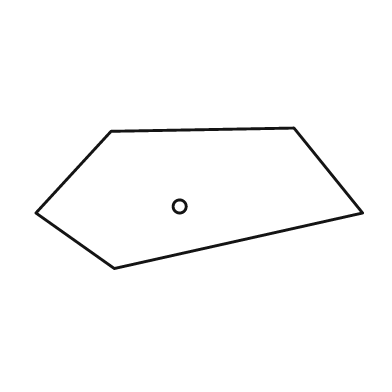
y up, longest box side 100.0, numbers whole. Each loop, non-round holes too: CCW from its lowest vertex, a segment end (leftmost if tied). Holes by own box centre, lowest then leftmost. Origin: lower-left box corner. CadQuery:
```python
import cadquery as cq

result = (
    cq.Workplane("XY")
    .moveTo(24.0, 0.0)
    .lineTo(100.0, 17.0)
    .lineTo(79.0, 43.0)
    .lineTo(23.0, 42.0)
    .lineTo(0.0, 17.0)
    .close()
    .moveTo(44.0, 19.0)
    .circle(2.0)
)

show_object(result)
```